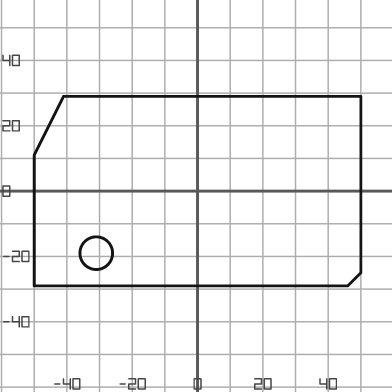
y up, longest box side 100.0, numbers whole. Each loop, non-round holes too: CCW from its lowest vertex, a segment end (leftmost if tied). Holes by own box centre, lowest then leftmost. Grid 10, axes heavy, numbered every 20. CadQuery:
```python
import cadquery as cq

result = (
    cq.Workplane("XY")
    .moveTo(-50.0, -29.0)
    .lineTo(46.0, -29.0)
    .lineTo(50.0, -25.0)
    .lineTo(50.0, 29.0)
    .lineTo(-41.0, 29.0)
    .lineTo(-50.0, 11.0)
    .close()
    .moveTo(-31.0, -19.0)
    .circle(5.0)
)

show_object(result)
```